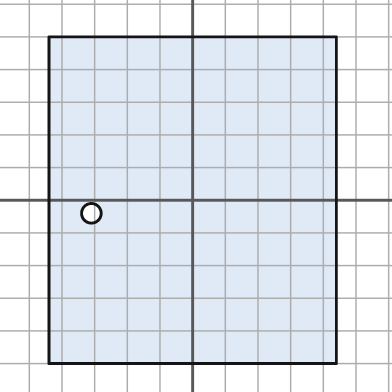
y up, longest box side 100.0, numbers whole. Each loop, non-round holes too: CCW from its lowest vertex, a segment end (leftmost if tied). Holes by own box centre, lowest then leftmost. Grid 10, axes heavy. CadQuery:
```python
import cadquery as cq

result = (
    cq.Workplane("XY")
    .moveTo(-44.0, -50.0)
    .lineTo(44.0, -50.0)
    .lineTo(44.0, 50.0)
    .lineTo(-44.0, 50.0)
    .close()
    .moveTo(-31.0, -4.0)
    .circle(3.0)
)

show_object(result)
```